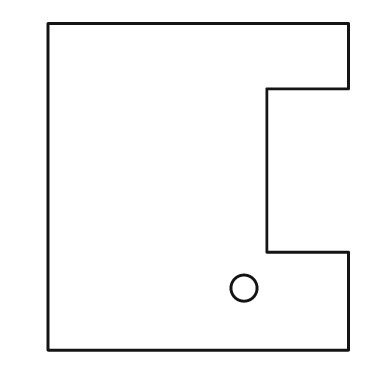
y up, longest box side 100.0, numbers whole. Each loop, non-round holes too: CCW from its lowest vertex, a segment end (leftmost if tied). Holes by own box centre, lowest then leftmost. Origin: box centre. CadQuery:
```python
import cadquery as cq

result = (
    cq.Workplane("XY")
    .moveTo(-46.0, -50.0)
    .lineTo(46.0, -50.0)
    .lineTo(46.0, -20.0)
    .lineTo(21.0, -20.0)
    .lineTo(21.0, 30.0)
    .lineTo(46.0, 30.0)
    .lineTo(46.0, 50.0)
    .lineTo(-46.0, 50.0)
    .close()
    .moveTo(14.0, -31.0)
    .circle(4.0)
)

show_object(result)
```